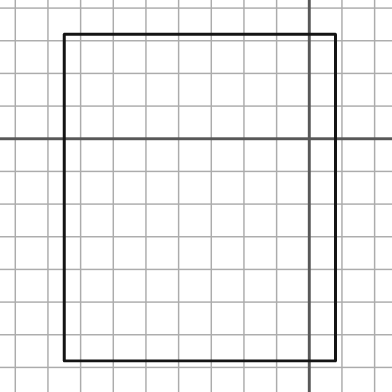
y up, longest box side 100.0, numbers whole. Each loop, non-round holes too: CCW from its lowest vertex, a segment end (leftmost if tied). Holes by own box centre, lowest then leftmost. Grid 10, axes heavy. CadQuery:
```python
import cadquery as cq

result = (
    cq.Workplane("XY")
    .moveTo(-75.0, -68.0)
    .lineTo(8.0, -68.0)
    .lineTo(8.0, 32.0)
    .lineTo(-75.0, 32.0)
    .close()
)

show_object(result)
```